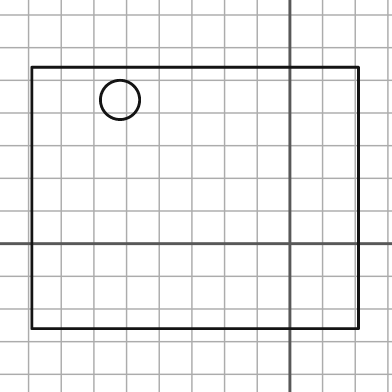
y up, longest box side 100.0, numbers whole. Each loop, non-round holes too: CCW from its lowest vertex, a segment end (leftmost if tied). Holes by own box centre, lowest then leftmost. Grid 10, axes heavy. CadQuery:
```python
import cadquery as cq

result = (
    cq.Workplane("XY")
    .moveTo(-79.0, -26.0)
    .lineTo(21.0, -26.0)
    .lineTo(21.0, 54.0)
    .lineTo(-79.0, 54.0)
    .close()
    .moveTo(-52.0, 44.0)
    .circle(6.0)
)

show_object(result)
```